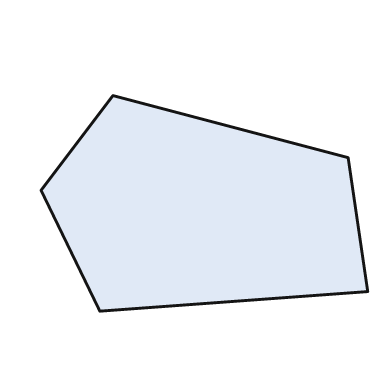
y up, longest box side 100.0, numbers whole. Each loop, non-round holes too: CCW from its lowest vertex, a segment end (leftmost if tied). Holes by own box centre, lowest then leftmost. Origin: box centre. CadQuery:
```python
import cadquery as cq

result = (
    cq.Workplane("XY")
    .moveTo(-32.0, -33.0)
    .lineTo(50.0, -27.0)
    .lineTo(44.0, 14.0)
    .lineTo(-28.0, 33.0)
    .lineTo(-50.0, 4.0)
    .close()
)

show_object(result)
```